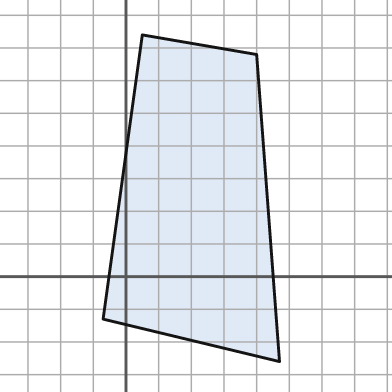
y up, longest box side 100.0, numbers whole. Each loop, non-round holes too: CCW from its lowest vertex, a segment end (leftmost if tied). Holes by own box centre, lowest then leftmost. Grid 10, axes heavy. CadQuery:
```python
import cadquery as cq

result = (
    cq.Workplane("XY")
    .moveTo(47.0, -26.0)
    .lineTo(40.0, 68.0)
    .lineTo(5.0, 74.0)
    .lineTo(-7.0, -13.0)
    .close()
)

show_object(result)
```